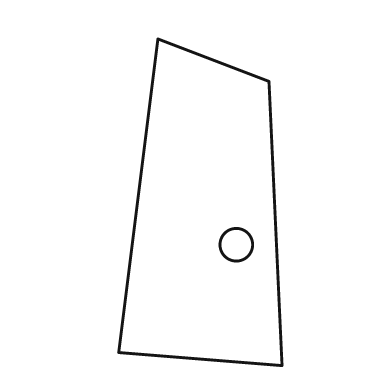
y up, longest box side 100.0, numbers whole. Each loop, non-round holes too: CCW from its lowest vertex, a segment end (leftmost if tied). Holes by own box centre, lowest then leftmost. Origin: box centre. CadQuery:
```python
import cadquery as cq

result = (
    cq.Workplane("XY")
    .moveTo(25.0, -50.0)
    .lineTo(21.0, 37.0)
    .lineTo(-13.0, 50.0)
    .lineTo(-25.0, -46.0)
    .close()
    .moveTo(11.0, -13.0)
    .circle(5.0)
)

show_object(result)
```